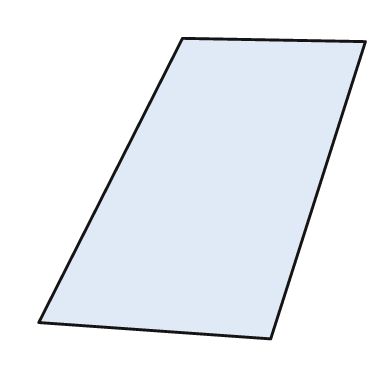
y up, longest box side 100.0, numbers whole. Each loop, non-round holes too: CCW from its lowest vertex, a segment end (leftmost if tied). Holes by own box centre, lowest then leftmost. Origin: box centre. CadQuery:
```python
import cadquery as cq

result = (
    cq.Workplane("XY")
    .moveTo(21.0, -46.0)
    .lineTo(50.0, 45.0)
    .lineTo(-6.0, 46.0)
    .lineTo(-50.0, -41.0)
    .close()
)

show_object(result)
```